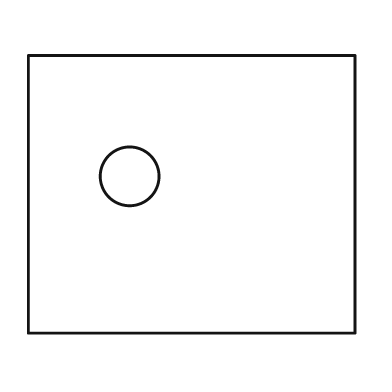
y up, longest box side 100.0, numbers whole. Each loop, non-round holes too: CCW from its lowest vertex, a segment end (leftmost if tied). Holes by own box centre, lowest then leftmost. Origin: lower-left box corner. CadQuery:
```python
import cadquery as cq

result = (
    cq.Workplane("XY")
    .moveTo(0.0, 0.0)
    .lineTo(100.0, 0.0)
    .lineTo(100.0, 85.0)
    .lineTo(0.0, 85.0)
    .close()
    .moveTo(31.0, 48.0)
    .circle(9.0)
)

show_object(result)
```